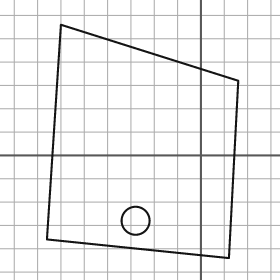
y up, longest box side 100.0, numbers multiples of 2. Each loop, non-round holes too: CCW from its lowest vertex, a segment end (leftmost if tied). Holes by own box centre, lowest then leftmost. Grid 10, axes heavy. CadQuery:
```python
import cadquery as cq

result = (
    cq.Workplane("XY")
    .moveTo(12.0, -44.0)
    .lineTo(16.0, 32.0)
    .lineTo(-60.0, 56.0)
    .lineTo(-66.0, -36.0)
    .close()
    .moveTo(-28.0, -28.0)
    .circle(6.0)
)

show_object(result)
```